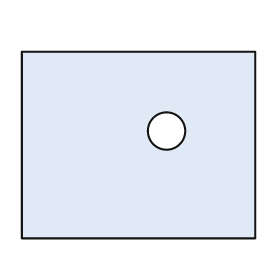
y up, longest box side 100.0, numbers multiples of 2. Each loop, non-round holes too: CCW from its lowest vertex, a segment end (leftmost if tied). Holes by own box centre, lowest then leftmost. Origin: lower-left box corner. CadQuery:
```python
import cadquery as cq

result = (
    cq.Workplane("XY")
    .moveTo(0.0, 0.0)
    .lineTo(100.0, 0.0)
    .lineTo(100.0, 80.0)
    .lineTo(0.0, 80.0)
    .close()
    .moveTo(62.0, 46.0)
    .circle(8.0)
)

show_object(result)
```